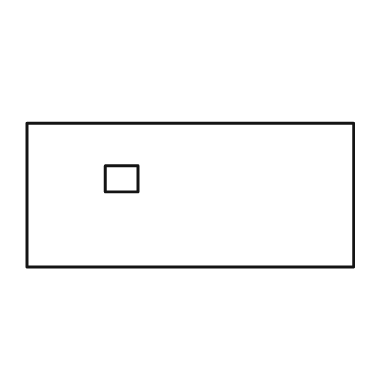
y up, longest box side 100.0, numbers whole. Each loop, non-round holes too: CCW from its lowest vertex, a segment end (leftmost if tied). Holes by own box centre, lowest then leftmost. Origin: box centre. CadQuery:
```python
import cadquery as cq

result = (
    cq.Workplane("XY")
    .moveTo(-50.0, -22.0)
    .lineTo(50.0, -22.0)
    .lineTo(50.0, 22.0)
    .lineTo(-50.0, 22.0)
    .close()
    .moveTo(-26.0, 1.0)
    .lineTo(-16.0, 1.0)
    .lineTo(-16.0, 9.0)
    .lineTo(-26.0, 9.0)
    .close()
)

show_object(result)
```